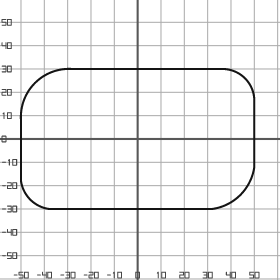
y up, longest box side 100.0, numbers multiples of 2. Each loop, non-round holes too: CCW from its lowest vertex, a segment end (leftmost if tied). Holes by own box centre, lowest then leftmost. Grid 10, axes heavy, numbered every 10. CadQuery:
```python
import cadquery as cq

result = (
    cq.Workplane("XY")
    .moveTo(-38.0, -30.0)
    .lineTo(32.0, -30.0)
    .threePointArc((44.0, -24.0), (50.0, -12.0))
    .lineTo(50.0, 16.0)
    .threePointArc((46.0, 26.0), (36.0, 30.0))
    .lineTo(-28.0, 30.0)
    .threePointArc((-44.0, 24.0), (-50.0, 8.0))
    .lineTo(-50.0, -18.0)
    .threePointArc((-46.0, -26.0), (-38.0, -30.0))
    .close()
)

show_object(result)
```